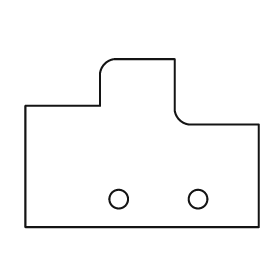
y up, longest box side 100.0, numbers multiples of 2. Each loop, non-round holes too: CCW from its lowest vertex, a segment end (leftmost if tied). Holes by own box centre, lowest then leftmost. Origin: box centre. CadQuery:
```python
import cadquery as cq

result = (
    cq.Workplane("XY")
    .moveTo(-50.0, -36.0)
    .lineTo(50.0, -36.0)
    .lineTo(50.0, 8.0)
    .lineTo(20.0, 8.0)
    .threePointArc((16.0, 10.0), (14.0, 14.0))
    .lineTo(14.0, 36.0)
    .lineTo(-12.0, 36.0)
    .threePointArc((-16.0, 34.0), (-18.0, 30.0))
    .lineTo(-18.0, 16.0)
    .lineTo(-50.0, 16.0)
    .close()
    .moveTo(-10.0, -24.0)
    .circle(4.0)
    .moveTo(24.0, -24.0)
    .circle(4.0)
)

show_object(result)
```